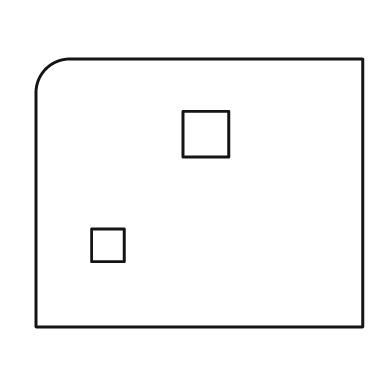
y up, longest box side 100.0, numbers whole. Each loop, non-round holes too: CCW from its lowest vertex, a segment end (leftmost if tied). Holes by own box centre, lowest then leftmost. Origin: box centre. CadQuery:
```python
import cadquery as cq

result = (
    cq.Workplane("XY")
    .moveTo(-50.0, -41.0)
    .lineTo(50.0, -41.0)
    .lineTo(50.0, 41.0)
    .lineTo(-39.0, 41.0)
    .threePointArc((-47.0, 38.0), (-50.0, 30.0))
    .close()
    .moveTo(-33.0, -21.0)
    .lineTo(-23.0, -21.0)
    .lineTo(-23.0, -11.0)
    .lineTo(-33.0, -11.0)
    .close()
    .moveTo(-5.0, 11.0)
    .lineTo(9.0, 11.0)
    .lineTo(9.0, 25.0)
    .lineTo(-5.0, 25.0)
    .close()
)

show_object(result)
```